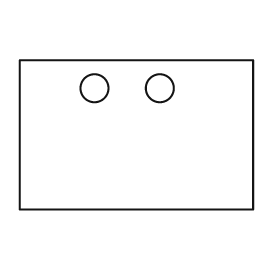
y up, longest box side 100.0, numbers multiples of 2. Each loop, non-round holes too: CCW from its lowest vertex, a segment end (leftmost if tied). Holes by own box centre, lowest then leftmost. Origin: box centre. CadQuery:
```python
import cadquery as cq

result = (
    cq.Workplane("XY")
    .moveTo(-50.0, -32.0)
    .lineTo(50.0, -32.0)
    .lineTo(50.0, 32.0)
    .lineTo(-50.0, 32.0)
    .close()
    .moveTo(-18.0, 20.0)
    .circle(6.0)
    .moveTo(10.0, 20.0)
    .circle(6.0)
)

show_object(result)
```